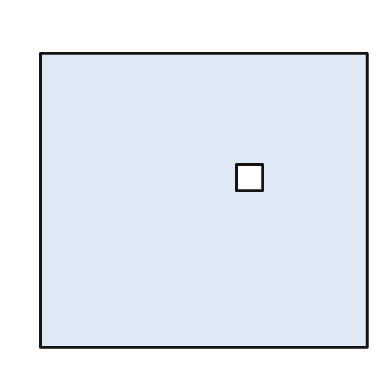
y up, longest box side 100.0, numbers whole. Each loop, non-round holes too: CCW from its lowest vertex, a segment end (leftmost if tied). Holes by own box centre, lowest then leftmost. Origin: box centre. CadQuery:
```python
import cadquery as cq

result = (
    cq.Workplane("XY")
    .moveTo(-50.0, -45.0)
    .lineTo(50.0, -45.0)
    .lineTo(50.0, 45.0)
    .lineTo(-50.0, 45.0)
    .close()
    .moveTo(10.0, 3.0)
    .lineTo(18.0, 3.0)
    .lineTo(18.0, 11.0)
    .lineTo(10.0, 11.0)
    .close()
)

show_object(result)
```